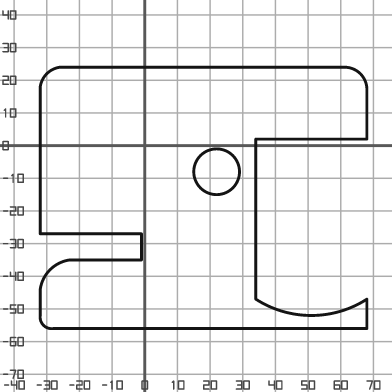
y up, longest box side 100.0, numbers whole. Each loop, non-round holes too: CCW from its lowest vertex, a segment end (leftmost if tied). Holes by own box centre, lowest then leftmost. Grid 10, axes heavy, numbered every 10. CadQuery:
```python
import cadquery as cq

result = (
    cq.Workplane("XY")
    .moveTo(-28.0, -56.0)
    .lineTo(68.0, -56.0)
    .lineTo(68.0, -47.0)
    .threePointArc((51.0, -52.0), (34.0, -47.0))
    .lineTo(34.0, 2.0)
    .lineTo(68.0, 2.0)
    .lineTo(68.0, 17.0)
    .threePointArc((66.0, 22.0), (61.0, 24.0))
    .lineTo(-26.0, 24.0)
    .threePointArc((-30.0, 22.0), (-32.0, 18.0))
    .lineTo(-32.0, -27.0)
    .lineTo(-1.0, -27.0)
    .lineTo(-1.0, -35.0)
    .lineTo(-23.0, -35.0)
    .threePointArc((-29.0, -38.0), (-32.0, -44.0))
    .lineTo(-32.0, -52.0)
    .threePointArc((-31.0, -55.0), (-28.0, -56.0))
    .close()
    .moveTo(22.0, -8.0)
    .circle(7.0)
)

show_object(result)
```